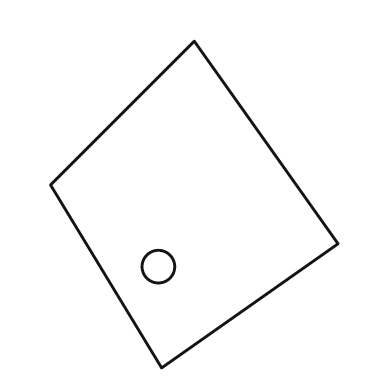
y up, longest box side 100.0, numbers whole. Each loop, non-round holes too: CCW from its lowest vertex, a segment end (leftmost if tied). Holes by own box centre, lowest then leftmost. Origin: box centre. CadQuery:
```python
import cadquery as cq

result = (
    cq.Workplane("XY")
    .moveTo(-10.0, -50.0)
    .lineTo(44.0, -12.0)
    .lineTo(0.0, 50.0)
    .lineTo(-44.0, 6.0)
    .close()
    .moveTo(-11.0, -19.0)
    .circle(5.0)
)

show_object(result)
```